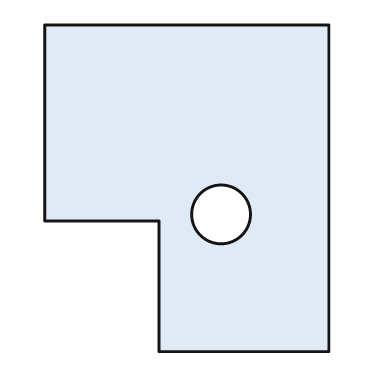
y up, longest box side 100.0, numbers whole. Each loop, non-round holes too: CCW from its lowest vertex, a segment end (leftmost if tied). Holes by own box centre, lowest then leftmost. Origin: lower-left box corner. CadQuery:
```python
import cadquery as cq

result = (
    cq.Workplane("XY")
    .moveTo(35.0, 0.0)
    .lineTo(87.0, 0.0)
    .lineTo(87.0, 100.0)
    .lineTo(0.0, 100.0)
    .lineTo(0.0, 40.0)
    .lineTo(35.0, 40.0)
    .close()
    .moveTo(54.0, 42.0)
    .circle(9.0)
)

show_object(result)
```